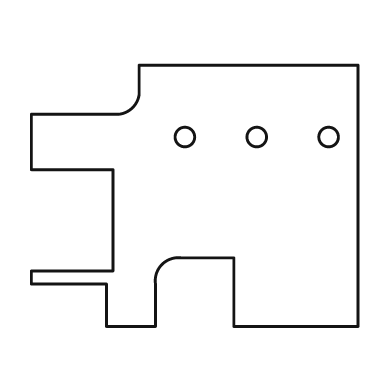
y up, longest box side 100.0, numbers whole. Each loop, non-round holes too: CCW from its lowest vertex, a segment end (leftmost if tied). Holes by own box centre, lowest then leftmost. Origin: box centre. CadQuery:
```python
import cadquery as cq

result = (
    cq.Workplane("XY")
    .moveTo(-27.0, -40.0)
    .lineTo(-12.0, -40.0)
    .lineTo(-12.0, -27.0)
    .threePointArc((-10.0, -21.0), (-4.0, -19.0))
    .lineTo(12.0, -19.0)
    .lineTo(12.0, -40.0)
    .lineTo(50.0, -40.0)
    .lineTo(50.0, 40.0)
    .lineTo(-17.0, 40.0)
    .lineTo(-17.0, 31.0)
    .threePointArc((-19.0, 27.0), (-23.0, 25.0))
    .lineTo(-50.0, 25.0)
    .lineTo(-50.0, 8.0)
    .lineTo(-25.0, 8.0)
    .lineTo(-25.0, -23.0)
    .lineTo(-50.0, -23.0)
    .lineTo(-50.0, -27.0)
    .lineTo(-27.0, -27.0)
    .close()
    .moveTo(-3.0, 18.0)
    .circle(3.0)
    .moveTo(19.0, 18.0)
    .circle(3.0)
    .moveTo(41.0, 18.0)
    .circle(3.0)
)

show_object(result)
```